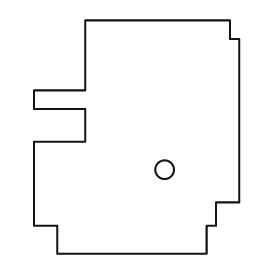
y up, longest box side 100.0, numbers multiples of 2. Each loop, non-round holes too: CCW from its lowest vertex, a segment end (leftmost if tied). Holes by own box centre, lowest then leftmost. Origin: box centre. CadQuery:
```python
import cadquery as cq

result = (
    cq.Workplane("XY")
    .moveTo(-34.0, -50.0)
    .lineTo(30.0, -50.0)
    .lineTo(30.0, -38.0)
    .lineTo(34.0, -38.0)
    .lineTo(34.0, -28.0)
    .lineTo(44.0, -28.0)
    .lineTo(44.0, 42.0)
    .lineTo(40.0, 42.0)
    .lineTo(40.0, 50.0)
    .lineTo(-22.0, 50.0)
    .lineTo(-22.0, 20.0)
    .lineTo(-44.0, 20.0)
    .lineTo(-44.0, 12.0)
    .lineTo(-22.0, 12.0)
    .lineTo(-22.0, -2.0)
    .lineTo(-44.0, -2.0)
    .lineTo(-44.0, -38.0)
    .lineTo(-34.0, -38.0)
    .close()
    .moveTo(12.0, -14.0)
    .circle(4.0)
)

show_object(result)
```